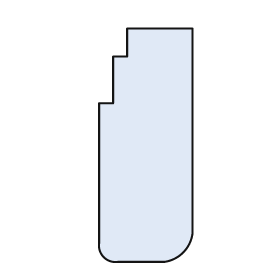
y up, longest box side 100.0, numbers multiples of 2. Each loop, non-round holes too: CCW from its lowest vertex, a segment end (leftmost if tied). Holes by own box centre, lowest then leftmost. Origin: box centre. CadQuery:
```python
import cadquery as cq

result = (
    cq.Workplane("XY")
    .moveTo(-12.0, -50.0)
    .lineTo(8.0, -50.0)
    .threePointArc((16.0, -46.0), (20.0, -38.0))
    .lineTo(20.0, 50.0)
    .lineTo(-8.0, 50.0)
    .lineTo(-8.0, 38.0)
    .lineTo(-14.0, 38.0)
    .lineTo(-14.0, 18.0)
    .lineTo(-20.0, 18.0)
    .lineTo(-20.0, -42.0)
    .threePointArc((-18.0, -48.0), (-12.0, -50.0))
    .close()
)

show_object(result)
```